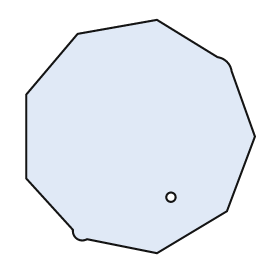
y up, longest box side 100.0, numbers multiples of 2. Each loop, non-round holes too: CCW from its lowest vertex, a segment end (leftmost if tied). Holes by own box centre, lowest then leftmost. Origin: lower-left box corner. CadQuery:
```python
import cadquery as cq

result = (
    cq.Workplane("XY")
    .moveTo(56.0, 0.0)
    .lineTo(86.0, 18.0)
    .lineTo(98.0, 50.0)
    .lineTo(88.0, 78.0)
    .threePointArc((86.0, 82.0), (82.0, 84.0))
    .lineTo(56.0, 100.0)
    .lineTo(22.0, 94.0)
    .lineTo(0.0, 68.0)
    .lineTo(0.0, 32.0)
    .lineTo(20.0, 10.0)
    .threePointArc((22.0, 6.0), (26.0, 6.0))
    .close()
    .moveTo(62.0, 24.0)
    .circle(2.0)
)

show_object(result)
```